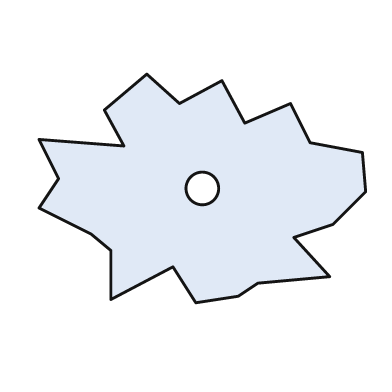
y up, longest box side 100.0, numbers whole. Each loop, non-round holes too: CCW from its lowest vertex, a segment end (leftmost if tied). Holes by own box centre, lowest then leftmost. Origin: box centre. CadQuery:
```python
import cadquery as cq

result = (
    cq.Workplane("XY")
    .moveTo(-2.0, -35.0)
    .lineTo(11.0, -33.0)
    .lineTo(17.0, -29.0)
    .lineTo(39.0, -27.0)
    .lineTo(28.0, -15.0)
    .lineTo(40.0, -11.0)
    .lineTo(50.0, -1.0)
    .lineTo(49.0, 11.0)
    .lineTo(33.0, 14.0)
    .lineTo(27.0, 26.0)
    .lineTo(13.0, 20.0)
    .lineTo(6.0, 33.0)
    .lineTo(-7.0, 26.0)
    .lineTo(-17.0, 35.0)
    .lineTo(-30.0, 24.0)
    .lineTo(-24.0, 13.0)
    .lineTo(-50.0, 15.0)
    .lineTo(-44.0, 3.0)
    .lineTo(-50.0, -6.0)
    .lineTo(-34.0, -14.0)
    .lineTo(-28.0, -19.0)
    .lineTo(-28.0, -34.0)
    .lineTo(-9.0, -24.0)
    .close()
    .moveTo(0.0, 0.0)
    .circle(5.0)
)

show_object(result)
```